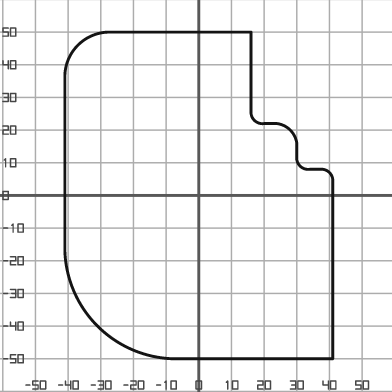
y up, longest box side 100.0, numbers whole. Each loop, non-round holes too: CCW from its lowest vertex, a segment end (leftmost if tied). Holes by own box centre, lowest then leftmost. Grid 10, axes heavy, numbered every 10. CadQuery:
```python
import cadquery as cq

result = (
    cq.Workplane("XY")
    .moveTo(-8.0, -50.0)
    .lineTo(41.0, -50.0)
    .lineTo(41.0, 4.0)
    .threePointArc((40.0, 7.0), (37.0, 8.0))
    .lineTo(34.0, 8.0)
    .threePointArc((31.0, 9.0), (30.0, 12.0))
    .lineTo(30.0, 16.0)
    .threePointArc((28.0, 20.0), (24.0, 22.0))
    .lineTo(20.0, 22.0)
    .threePointArc((17.0, 23.0), (16.0, 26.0))
    .lineTo(16.0, 50.0)
    .lineTo(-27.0, 50.0)
    .threePointArc((-37.0, 46.0), (-41.0, 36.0))
    .lineTo(-41.0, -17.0)
    .threePointArc((-31.0, -40.0), (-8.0, -50.0))
    .close()
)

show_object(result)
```